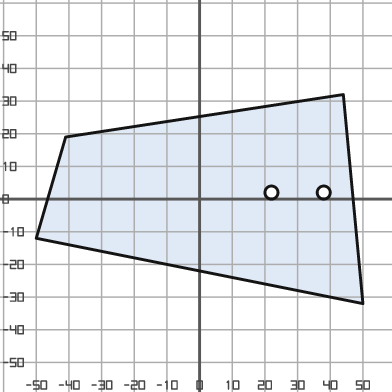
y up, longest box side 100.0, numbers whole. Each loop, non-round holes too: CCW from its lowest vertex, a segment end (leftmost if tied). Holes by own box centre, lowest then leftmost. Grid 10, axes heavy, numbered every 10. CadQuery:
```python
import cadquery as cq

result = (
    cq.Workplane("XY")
    .moveTo(50.0, -32.0)
    .lineTo(44.0, 32.0)
    .lineTo(-41.0, 19.0)
    .lineTo(-50.0, -12.0)
    .close()
    .moveTo(22.0, 2.0)
    .circle(2.0)
    .moveTo(38.0, 2.0)
    .circle(2.0)
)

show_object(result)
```